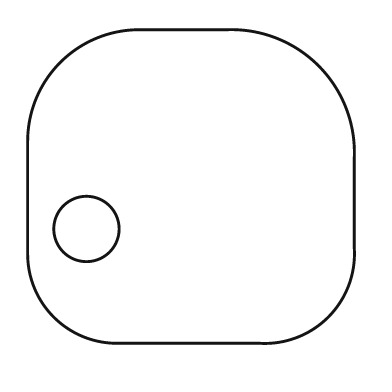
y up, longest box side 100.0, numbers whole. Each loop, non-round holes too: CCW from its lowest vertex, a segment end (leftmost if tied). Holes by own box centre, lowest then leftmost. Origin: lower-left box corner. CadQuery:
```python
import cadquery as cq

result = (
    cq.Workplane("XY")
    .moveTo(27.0, 0.0)
    .lineTo(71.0, 0.0)
    .threePointArc((92.0, 8.0), (100.0, 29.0))
    .lineTo(100.0, 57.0)
    .threePointArc((89.0, 85.0), (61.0, 96.0))
    .lineTo(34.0, 96.0)
    .threePointArc((10.0, 86.0), (0.0, 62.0))
    .lineTo(0.0, 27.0)
    .threePointArc((8.0, 8.0), (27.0, 0.0))
    .close()
    .moveTo(18.0, 35.0)
    .circle(10.0)
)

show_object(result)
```